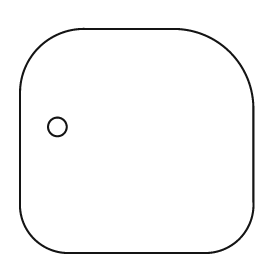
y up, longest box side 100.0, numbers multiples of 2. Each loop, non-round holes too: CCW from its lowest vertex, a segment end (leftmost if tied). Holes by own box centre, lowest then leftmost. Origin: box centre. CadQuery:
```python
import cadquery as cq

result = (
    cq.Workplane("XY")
    .moveTo(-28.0, -48.0)
    .lineTo(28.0, -48.0)
    .threePointArc((44.0, -42.0), (50.0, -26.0))
    .lineTo(50.0, 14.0)
    .threePointArc((40.0, 38.0), (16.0, 48.0))
    .lineTo(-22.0, 48.0)
    .threePointArc((-42.0, 40.0), (-50.0, 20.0))
    .lineTo(-50.0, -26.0)
    .threePointArc((-44.0, -42.0), (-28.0, -48.0))
    .close()
    .moveTo(-34.0, 6.0)
    .circle(4.0)
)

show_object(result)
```